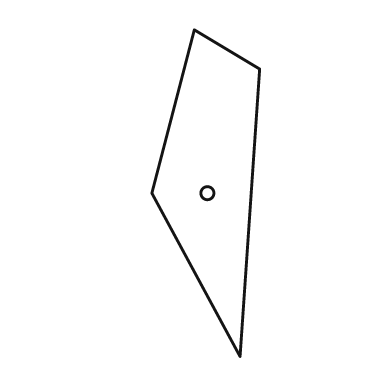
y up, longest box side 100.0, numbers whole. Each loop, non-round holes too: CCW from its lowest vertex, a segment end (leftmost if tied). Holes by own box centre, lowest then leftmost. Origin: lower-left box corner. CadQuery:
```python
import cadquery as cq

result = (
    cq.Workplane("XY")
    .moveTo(27.0, 0.0)
    .lineTo(33.0, 88.0)
    .lineTo(13.0, 100.0)
    .lineTo(0.0, 50.0)
    .close()
    .moveTo(17.0, 50.0)
    .circle(2.0)
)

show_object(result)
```